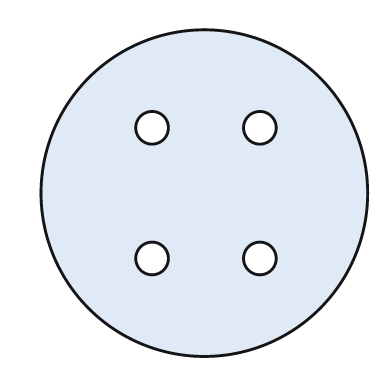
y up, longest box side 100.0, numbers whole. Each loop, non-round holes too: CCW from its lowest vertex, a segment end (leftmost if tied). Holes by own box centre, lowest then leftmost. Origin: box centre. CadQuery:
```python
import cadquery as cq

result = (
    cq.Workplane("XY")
    .moveTo(0.0, 0.0)
    .circle(50.0)
    .moveTo(-16.0, -20.0)
    .circle(5.0)
    .moveTo(17.0, -20.0)
    .circle(5.0)
    .moveTo(-16.0, 20.0)
    .circle(5.0)
    .moveTo(17.0, 20.0)
    .circle(5.0)
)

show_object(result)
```